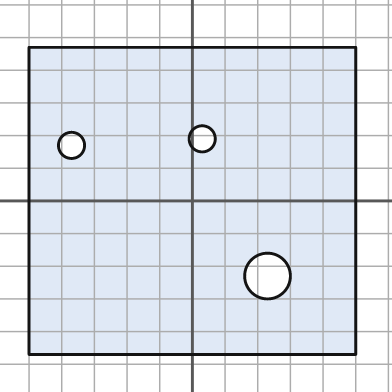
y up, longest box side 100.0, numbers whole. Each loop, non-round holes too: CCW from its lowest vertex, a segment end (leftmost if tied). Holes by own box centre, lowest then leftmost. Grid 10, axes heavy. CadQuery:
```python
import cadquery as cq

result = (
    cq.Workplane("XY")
    .moveTo(-50.0, -47.0)
    .lineTo(50.0, -47.0)
    .lineTo(50.0, 47.0)
    .lineTo(-50.0, 47.0)
    .close()
    .moveTo(23.0, -23.0)
    .circle(7.0)
    .moveTo(-37.0, 17.0)
    .circle(4.0)
    .moveTo(3.0, 19.0)
    .circle(4.0)
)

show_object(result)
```